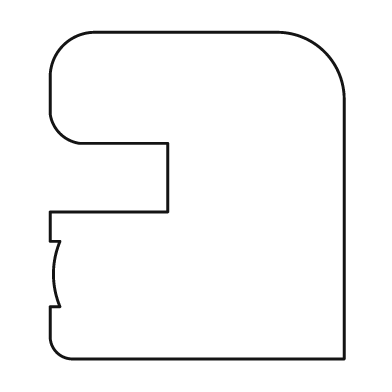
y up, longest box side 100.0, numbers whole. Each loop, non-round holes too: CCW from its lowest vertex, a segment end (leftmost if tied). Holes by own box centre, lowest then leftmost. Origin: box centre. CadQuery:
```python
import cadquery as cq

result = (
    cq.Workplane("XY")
    .moveTo(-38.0, -50.0)
    .lineTo(45.0, -50.0)
    .lineTo(45.0, 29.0)
    .threePointArc((39.0, 44.0), (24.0, 50.0))
    .lineTo(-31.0, 50.0)
    .threePointArc((-41.0, 46.0), (-45.0, 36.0))
    .lineTo(-45.0, 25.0)
    .threePointArc((-42.0, 19.0), (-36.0, 16.0))
    .lineTo(-9.0, 16.0)
    .lineTo(-9.0, -5.0)
    .lineTo(-45.0, -5.0)
    .lineTo(-45.0, -14.0)
    .lineTo(-42.0, -14.0)
    .threePointArc((-44.0, -24.0), (-42.0, -34.0))
    .lineTo(-45.0, -34.0)
    .lineTo(-45.0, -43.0)
    .threePointArc((-43.0, -48.0), (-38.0, -50.0))
    .close()
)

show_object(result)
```